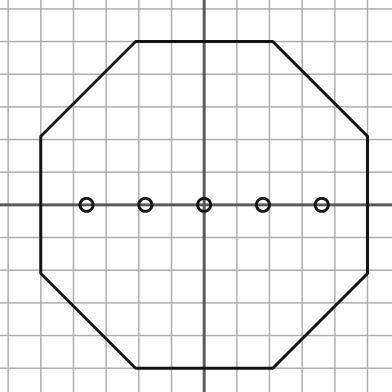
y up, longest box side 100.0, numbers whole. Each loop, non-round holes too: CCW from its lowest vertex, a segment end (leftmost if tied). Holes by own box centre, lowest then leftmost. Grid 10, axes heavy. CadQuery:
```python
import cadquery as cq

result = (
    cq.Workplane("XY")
    .moveTo(-21.0, -50.0)
    .lineTo(21.0, -50.0)
    .lineTo(50.0, -21.0)
    .lineTo(50.0, 21.0)
    .lineTo(21.0, 50.0)
    .lineTo(-21.0, 50.0)
    .lineTo(-50.0, 21.0)
    .lineTo(-50.0, -21.0)
    .close()
    .moveTo(-36.0, 0.0)
    .circle(2.0)
    .moveTo(-18.0, 0.0)
    .circle(2.0)
    .moveTo(0.0, 0.0)
    .circle(2.0)
    .moveTo(18.0, 0.0)
    .circle(2.0)
    .moveTo(36.0, 0.0)
    .circle(2.0)
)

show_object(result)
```